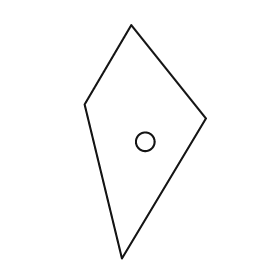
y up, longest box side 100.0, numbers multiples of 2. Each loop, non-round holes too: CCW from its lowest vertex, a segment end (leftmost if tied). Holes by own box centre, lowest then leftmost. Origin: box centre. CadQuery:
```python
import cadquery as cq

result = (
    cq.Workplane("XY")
    .moveTo(-10.0, -50.0)
    .lineTo(26.0, 10.0)
    .lineTo(-6.0, 50.0)
    .lineTo(-26.0, 16.0)
    .close()
    .moveTo(0.0, 0.0)
    .circle(4.0)
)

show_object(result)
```